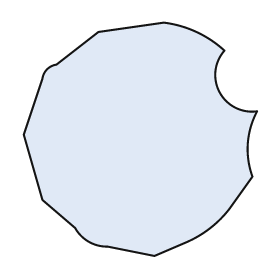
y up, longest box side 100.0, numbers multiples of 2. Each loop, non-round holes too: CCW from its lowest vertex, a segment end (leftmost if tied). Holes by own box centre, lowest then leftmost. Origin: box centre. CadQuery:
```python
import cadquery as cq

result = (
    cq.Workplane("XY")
    .moveTo(6.0, -50.0)
    .lineTo(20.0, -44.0)
    .threePointArc((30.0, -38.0), (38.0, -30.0))
    .lineTo(48.0, -16.0)
    .threePointArc((46.0, -2.0), (50.0, 12.0))
    .threePointArc((34.0, 20.0), (36.0, 38.0))
    .threePointArc((24.0, 46.0), (10.0, 50.0))
    .lineTo(-18.0, 46.0)
    .lineTo(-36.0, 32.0)
    .threePointArc((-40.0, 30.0), (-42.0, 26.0))
    .lineTo(-50.0, 2.0)
    .lineTo(-42.0, -26.0)
    .lineTo(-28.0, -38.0)
    .threePointArc((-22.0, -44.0), (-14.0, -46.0))
    .close()
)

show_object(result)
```